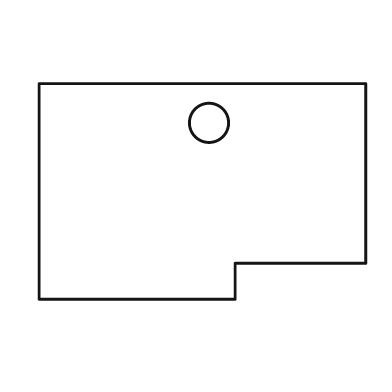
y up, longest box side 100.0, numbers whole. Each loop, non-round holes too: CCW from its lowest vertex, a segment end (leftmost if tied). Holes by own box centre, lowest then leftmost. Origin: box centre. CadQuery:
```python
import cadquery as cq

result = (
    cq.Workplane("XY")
    .moveTo(-50.0, -33.0)
    .lineTo(10.0, -33.0)
    .lineTo(10.0, -22.0)
    .lineTo(50.0, -22.0)
    .lineTo(50.0, 33.0)
    .lineTo(-50.0, 33.0)
    .close()
    .moveTo(2.0, 21.0)
    .circle(6.0)
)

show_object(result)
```